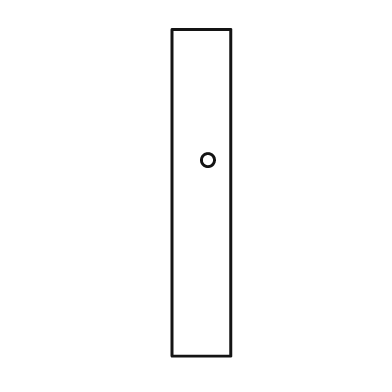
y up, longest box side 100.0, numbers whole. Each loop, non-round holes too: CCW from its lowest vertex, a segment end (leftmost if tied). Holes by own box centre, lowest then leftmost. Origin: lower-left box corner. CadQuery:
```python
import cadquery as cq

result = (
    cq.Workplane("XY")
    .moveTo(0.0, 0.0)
    .lineTo(18.0, 0.0)
    .lineTo(18.0, 100.0)
    .lineTo(0.0, 100.0)
    .close()
    .moveTo(11.0, 60.0)
    .circle(2.0)
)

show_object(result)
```